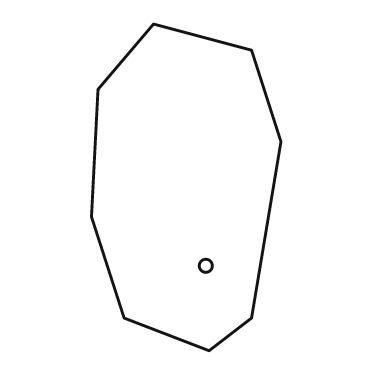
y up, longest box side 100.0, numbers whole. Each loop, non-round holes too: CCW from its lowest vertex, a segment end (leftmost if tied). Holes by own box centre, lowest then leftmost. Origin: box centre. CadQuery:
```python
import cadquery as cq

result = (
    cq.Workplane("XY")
    .moveTo(7.0, -50.0)
    .lineTo(20.0, -40.0)
    .lineTo(29.0, 14.0)
    .lineTo(20.0, 42.0)
    .lineTo(-10.0, 50.0)
    .lineTo(-27.0, 30.0)
    .lineTo(-29.0, -9.0)
    .lineTo(-19.0, -40.0)
    .close()
    .moveTo(6.0, -24.0)
    .circle(2.0)
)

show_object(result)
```